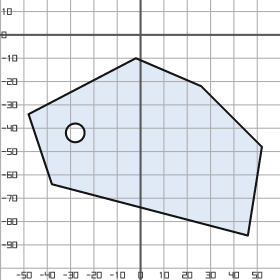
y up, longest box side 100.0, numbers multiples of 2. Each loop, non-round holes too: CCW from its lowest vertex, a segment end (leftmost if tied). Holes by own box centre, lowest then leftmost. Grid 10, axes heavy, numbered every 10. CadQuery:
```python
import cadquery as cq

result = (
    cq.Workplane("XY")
    .moveTo(46.0, -86.0)
    .lineTo(52.0, -48.0)
    .lineTo(26.0, -22.0)
    .lineTo(-2.0, -10.0)
    .lineTo(-48.0, -34.0)
    .lineTo(-38.0, -64.0)
    .close()
    .moveTo(-28.0, -42.0)
    .circle(4.0)
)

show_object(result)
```